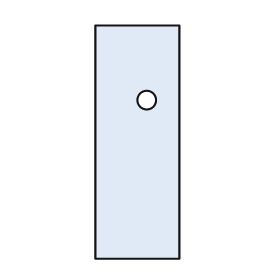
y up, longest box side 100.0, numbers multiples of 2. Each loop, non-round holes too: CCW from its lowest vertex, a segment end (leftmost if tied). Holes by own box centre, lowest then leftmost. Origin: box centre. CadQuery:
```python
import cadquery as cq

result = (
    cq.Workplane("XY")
    .moveTo(-18.0, -50.0)
    .lineTo(18.0, -50.0)
    .lineTo(18.0, 50.0)
    .lineTo(-18.0, 50.0)
    .close()
    .moveTo(4.0, 18.0)
    .circle(4.0)
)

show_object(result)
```